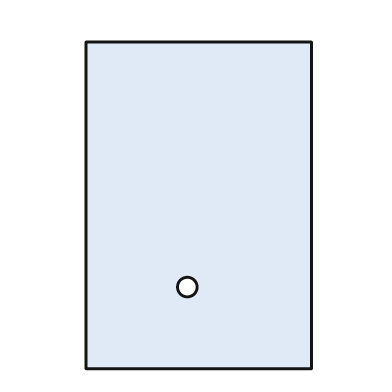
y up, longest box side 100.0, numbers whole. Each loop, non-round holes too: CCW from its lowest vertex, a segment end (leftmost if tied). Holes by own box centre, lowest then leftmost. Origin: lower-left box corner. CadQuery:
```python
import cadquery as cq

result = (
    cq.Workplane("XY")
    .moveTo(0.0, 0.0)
    .lineTo(69.0, 0.0)
    .lineTo(69.0, 100.0)
    .lineTo(0.0, 100.0)
    .close()
    .moveTo(31.0, 25.0)
    .circle(3.0)
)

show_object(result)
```